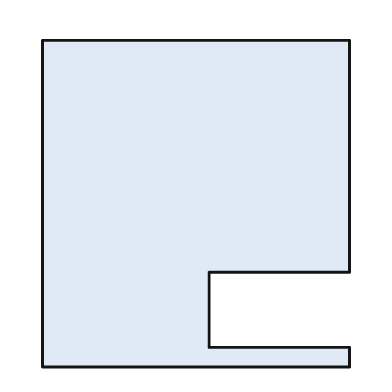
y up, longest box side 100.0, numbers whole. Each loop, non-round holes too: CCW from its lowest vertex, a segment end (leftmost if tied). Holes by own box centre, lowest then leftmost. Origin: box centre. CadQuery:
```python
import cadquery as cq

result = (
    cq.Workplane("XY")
    .moveTo(-47.0, -50.0)
    .lineTo(47.0, -50.0)
    .lineTo(47.0, -44.0)
    .lineTo(4.0, -44.0)
    .lineTo(4.0, -21.0)
    .lineTo(47.0, -21.0)
    .lineTo(47.0, 50.0)
    .lineTo(-47.0, 50.0)
    .close()
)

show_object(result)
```